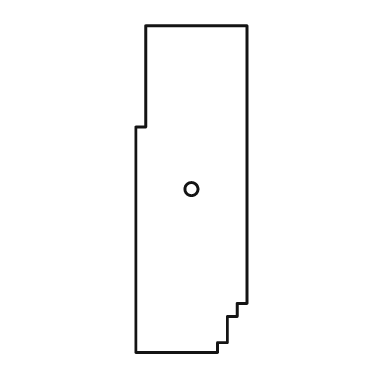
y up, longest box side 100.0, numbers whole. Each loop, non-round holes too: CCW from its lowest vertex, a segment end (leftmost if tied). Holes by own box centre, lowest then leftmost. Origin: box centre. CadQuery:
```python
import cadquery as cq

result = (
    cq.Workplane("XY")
    .moveTo(-17.0, -50.0)
    .lineTo(8.0, -50.0)
    .lineTo(8.0, -47.0)
    .lineTo(11.0, -47.0)
    .lineTo(11.0, -39.0)
    .lineTo(14.0, -39.0)
    .lineTo(14.0, -35.0)
    .lineTo(17.0, -35.0)
    .lineTo(17.0, 50.0)
    .lineTo(-14.0, 50.0)
    .lineTo(-14.0, 19.0)
    .lineTo(-17.0, 19.0)
    .close()
    .moveTo(0.0, 0.0)
    .circle(2.0)
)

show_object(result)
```